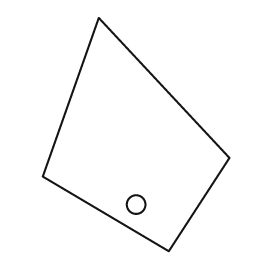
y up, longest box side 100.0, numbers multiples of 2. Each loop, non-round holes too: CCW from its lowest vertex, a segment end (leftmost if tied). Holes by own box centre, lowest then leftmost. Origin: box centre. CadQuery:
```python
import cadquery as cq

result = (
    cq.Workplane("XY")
    .moveTo(14.0, -50.0)
    .lineTo(40.0, -10.0)
    .lineTo(-16.0, 50.0)
    .lineTo(-40.0, -18.0)
    .close()
    .moveTo(0.0, -30.0)
    .circle(4.0)
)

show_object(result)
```